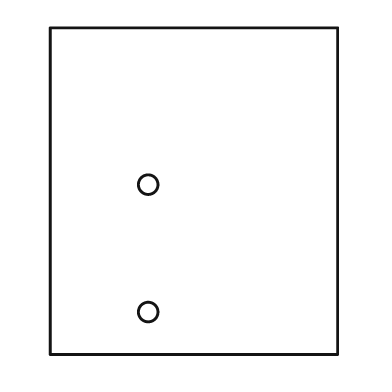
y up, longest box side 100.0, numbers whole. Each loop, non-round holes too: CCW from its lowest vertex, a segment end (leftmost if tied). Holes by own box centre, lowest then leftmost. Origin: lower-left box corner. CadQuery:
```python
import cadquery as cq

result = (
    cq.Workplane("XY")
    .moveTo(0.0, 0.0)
    .lineTo(88.0, 0.0)
    .lineTo(88.0, 100.0)
    .lineTo(0.0, 100.0)
    .close()
    .moveTo(30.0, 13.0)
    .circle(3.0)
    .moveTo(30.0, 52.0)
    .circle(3.0)
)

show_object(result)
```